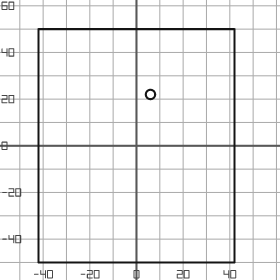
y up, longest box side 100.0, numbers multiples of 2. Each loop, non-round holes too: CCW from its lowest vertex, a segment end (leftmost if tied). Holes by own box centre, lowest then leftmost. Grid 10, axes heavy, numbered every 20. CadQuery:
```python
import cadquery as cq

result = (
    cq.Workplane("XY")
    .moveTo(-42.0, -50.0)
    .lineTo(42.0, -50.0)
    .lineTo(42.0, 50.0)
    .lineTo(-42.0, 50.0)
    .close()
    .moveTo(6.0, 22.0)
    .circle(2.0)
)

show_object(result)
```